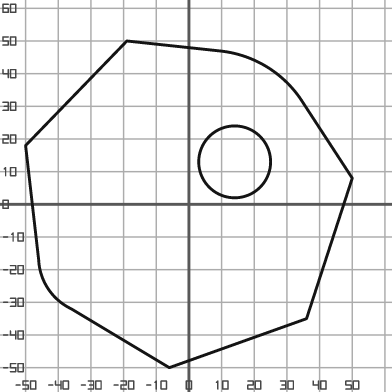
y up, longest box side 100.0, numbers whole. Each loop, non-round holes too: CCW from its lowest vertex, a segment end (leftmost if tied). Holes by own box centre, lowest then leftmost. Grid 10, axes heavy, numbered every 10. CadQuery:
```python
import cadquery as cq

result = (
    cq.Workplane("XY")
    .moveTo(-6.0, -50.0)
    .lineTo(36.0, -35.0)
    .lineTo(50.0, 8.0)
    .lineTo(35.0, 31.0)
    .threePointArc((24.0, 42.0), (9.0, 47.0))
    .lineTo(-19.0, 50.0)
    .lineTo(-50.0, 18.0)
    .lineTo(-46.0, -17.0)
    .threePointArc((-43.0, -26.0), (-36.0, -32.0))
    .close()
    .moveTo(14.0, 13.0)
    .circle(11.0)
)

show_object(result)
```